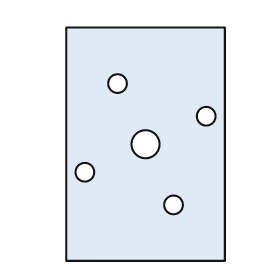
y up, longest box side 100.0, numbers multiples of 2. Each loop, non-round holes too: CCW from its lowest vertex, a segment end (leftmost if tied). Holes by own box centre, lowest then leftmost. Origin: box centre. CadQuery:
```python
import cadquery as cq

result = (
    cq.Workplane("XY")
    .moveTo(-34.0, -50.0)
    .lineTo(34.0, -50.0)
    .lineTo(34.0, 50.0)
    .lineTo(-34.0, 50.0)
    .close()
    .moveTo(12.0, -26.0)
    .circle(4.0)
    .moveTo(-26.0, -12.0)
    .circle(4.0)
    .moveTo(0.0, 0.0)
    .circle(6.0)
    .moveTo(26.0, 12.0)
    .circle(4.0)
    .moveTo(-12.0, 26.0)
    .circle(4.0)
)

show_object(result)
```